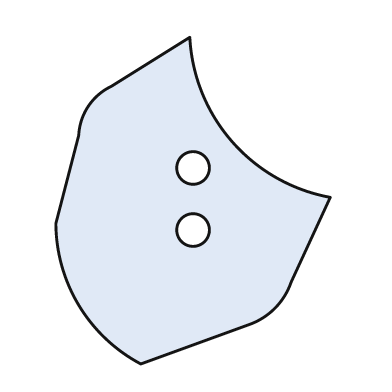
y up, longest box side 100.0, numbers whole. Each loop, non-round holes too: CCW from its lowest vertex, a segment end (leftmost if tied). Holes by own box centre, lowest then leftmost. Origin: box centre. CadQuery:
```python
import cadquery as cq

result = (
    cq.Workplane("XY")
    .moveTo(-16.0, -50.0)
    .lineTo(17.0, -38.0)
    .threePointArc((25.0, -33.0), (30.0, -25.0))
    .lineTo(42.0, 1.0)
    .threePointArc((12.0, 18.0), (-1.0, 50.0))
    .lineTo(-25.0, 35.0)
    .threePointArc((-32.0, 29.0), (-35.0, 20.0))
    .lineTo(-42.0, -7.0)
    .threePointArc((-35.0, -32.0), (-16.0, -50.0))
    .close()
    .moveTo(0.0, -9.0)
    .circle(5.0)
    .moveTo(0.0, 10.0)
    .circle(5.0)
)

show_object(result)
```